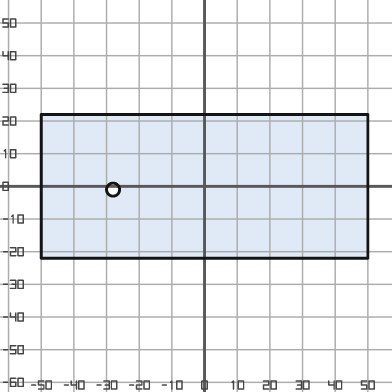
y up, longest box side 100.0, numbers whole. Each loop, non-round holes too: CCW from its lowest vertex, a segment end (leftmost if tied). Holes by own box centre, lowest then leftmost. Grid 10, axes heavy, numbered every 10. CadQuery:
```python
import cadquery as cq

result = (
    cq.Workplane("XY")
    .moveTo(-50.0, -22.0)
    .lineTo(50.0, -22.0)
    .lineTo(50.0, 22.0)
    .lineTo(-50.0, 22.0)
    .close()
    .moveTo(-28.0, -1.0)
    .circle(2.0)
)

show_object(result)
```